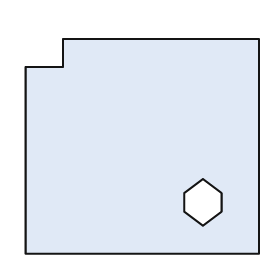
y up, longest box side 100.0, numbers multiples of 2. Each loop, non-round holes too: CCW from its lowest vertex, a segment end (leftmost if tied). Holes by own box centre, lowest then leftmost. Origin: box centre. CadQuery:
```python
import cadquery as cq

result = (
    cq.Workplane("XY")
    .moveTo(-50.0, -46.0)
    .lineTo(50.0, -46.0)
    .lineTo(50.0, 46.0)
    .lineTo(-34.0, 46.0)
    .lineTo(-34.0, 34.0)
    .lineTo(-50.0, 34.0)
    .close()
    .moveTo(26.0, -34.0)
    .lineTo(34.0, -28.0)
    .lineTo(34.0, -20.0)
    .lineTo(26.0, -14.0)
    .lineTo(18.0, -20.0)
    .lineTo(18.0, -28.0)
    .close()
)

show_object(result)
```